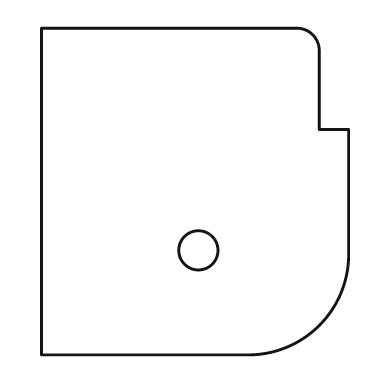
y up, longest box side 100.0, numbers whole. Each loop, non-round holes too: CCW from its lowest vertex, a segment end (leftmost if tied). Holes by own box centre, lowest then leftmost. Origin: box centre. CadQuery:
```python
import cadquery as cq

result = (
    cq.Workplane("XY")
    .moveTo(-47.0, -50.0)
    .lineTo(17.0, -50.0)
    .threePointArc((38.0, -41.0), (47.0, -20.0))
    .lineTo(47.0, 19.0)
    .lineTo(38.0, 19.0)
    .lineTo(38.0, 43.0)
    .threePointArc((36.0, 48.0), (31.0, 50.0))
    .lineTo(-47.0, 50.0)
    .close()
    .moveTo(1.0, -18.0)
    .circle(6.0)
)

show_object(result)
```